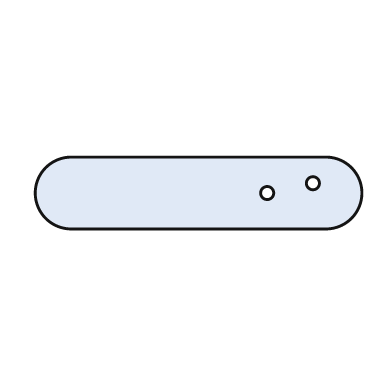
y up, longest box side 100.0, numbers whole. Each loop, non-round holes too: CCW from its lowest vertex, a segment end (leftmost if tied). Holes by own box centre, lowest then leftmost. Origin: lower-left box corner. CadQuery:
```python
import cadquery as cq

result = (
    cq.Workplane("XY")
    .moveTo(11.0, 0.0)
    .lineTo(89.0, 0.0)
    .threePointArc((100.0, 11.0), (89.0, 22.0))
    .lineTo(11.0, 22.0)
    .threePointArc((0.0, 11.0), (11.0, 0.0))
    .close()
    .moveTo(71.0, 11.0)
    .circle(2.0)
    .moveTo(85.0, 14.0)
    .circle(2.0)
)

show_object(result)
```